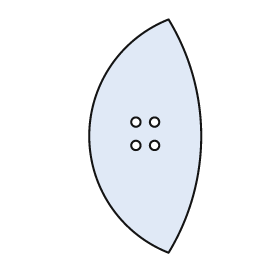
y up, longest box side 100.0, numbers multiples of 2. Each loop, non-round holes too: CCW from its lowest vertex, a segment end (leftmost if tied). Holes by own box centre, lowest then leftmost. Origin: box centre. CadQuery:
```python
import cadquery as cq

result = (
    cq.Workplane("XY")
    .moveTo(10.0, -50.0)
    .threePointArc((24.0, 0.0), (10.0, 50.0))
    .threePointArc((-24.0, 0.0), (10.0, -50.0))
    .close()
    .moveTo(-4.0, -4.0)
    .circle(2.0)
    .moveTo(4.0, -4.0)
    .circle(2.0)
    .moveTo(-4.0, 6.0)
    .circle(2.0)
    .moveTo(4.0, 6.0)
    .circle(2.0)
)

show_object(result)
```